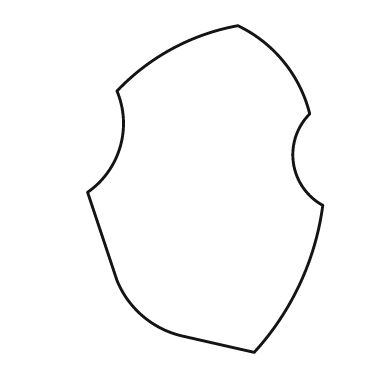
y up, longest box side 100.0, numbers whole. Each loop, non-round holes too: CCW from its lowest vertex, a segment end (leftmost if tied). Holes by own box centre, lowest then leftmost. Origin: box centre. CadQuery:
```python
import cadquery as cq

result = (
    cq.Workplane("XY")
    .moveTo(15.0, -50.0)
    .threePointArc((29.0, -29.0), (36.0, -5.0))
    .threePointArc((27.0, 8.0), (32.0, 23.0))
    .threePointArc((24.0, 39.0), (10.0, 50.0))
    .threePointArc((-10.0, 43.0), (-27.0, 30.0))
    .threePointArc((-26.0, 13.0), (-36.0, -1.0))
    .lineTo(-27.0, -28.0)
    .threePointArc((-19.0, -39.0), (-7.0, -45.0))
    .close()
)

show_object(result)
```